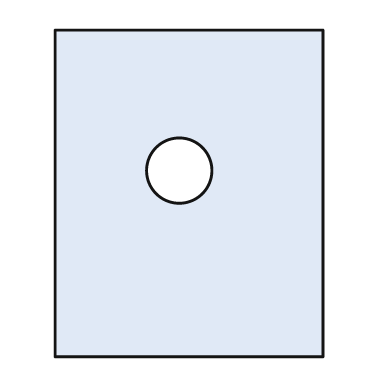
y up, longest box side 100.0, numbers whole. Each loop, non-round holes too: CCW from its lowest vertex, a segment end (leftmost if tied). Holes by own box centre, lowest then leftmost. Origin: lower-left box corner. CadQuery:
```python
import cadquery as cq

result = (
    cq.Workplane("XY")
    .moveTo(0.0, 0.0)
    .lineTo(82.0, 0.0)
    .lineTo(82.0, 100.0)
    .lineTo(0.0, 100.0)
    .close()
    .moveTo(38.0, 57.0)
    .circle(10.0)
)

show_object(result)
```